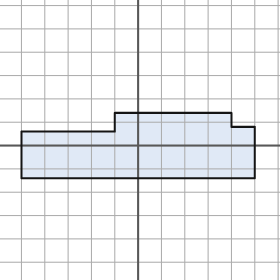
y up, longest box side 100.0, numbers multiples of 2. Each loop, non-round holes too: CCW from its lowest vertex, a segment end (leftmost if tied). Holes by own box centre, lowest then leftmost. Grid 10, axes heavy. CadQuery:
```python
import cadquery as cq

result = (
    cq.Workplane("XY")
    .moveTo(-50.0, -14.0)
    .lineTo(50.0, -14.0)
    .lineTo(50.0, 8.0)
    .lineTo(40.0, 8.0)
    .lineTo(40.0, 14.0)
    .lineTo(-10.0, 14.0)
    .lineTo(-10.0, 6.0)
    .lineTo(-50.0, 6.0)
    .close()
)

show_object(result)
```